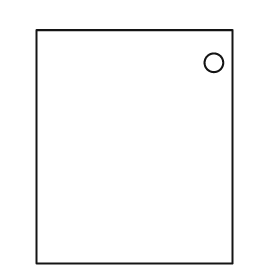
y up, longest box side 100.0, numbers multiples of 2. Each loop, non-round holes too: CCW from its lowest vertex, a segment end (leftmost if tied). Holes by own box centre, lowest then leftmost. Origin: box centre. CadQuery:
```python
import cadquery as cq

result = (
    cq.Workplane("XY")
    .moveTo(-42.0, -50.0)
    .lineTo(42.0, -50.0)
    .lineTo(42.0, 50.0)
    .lineTo(-42.0, 50.0)
    .close()
    .moveTo(34.0, 36.0)
    .circle(4.0)
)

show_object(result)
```